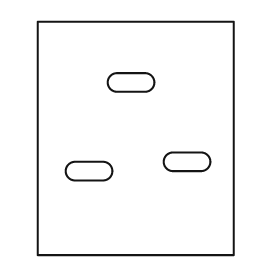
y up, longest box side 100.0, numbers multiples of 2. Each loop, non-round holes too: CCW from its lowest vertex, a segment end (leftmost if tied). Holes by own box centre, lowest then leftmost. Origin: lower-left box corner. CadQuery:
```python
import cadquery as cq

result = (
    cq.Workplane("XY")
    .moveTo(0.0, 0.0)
    .lineTo(84.0, 0.0)
    .lineTo(84.0, 100.0)
    .lineTo(0.0, 100.0)
    .close()
    .moveTo(16.0, 32.0)
    .lineTo(28.0, 32.0)
    .threePointArc((32.0, 36.0), (28.0, 40.0))
    .lineTo(16.0, 40.0)
    .threePointArc((12.0, 36.0), (16.0, 32.0))
    .close()
    .moveTo(58.0, 36.0)
    .lineTo(70.0, 36.0)
    .threePointArc((74.0, 40.0), (70.0, 44.0))
    .lineTo(58.0, 44.0)
    .threePointArc((54.0, 40.0), (58.0, 36.0))
    .close()
    .moveTo(34.0, 70.0)
    .lineTo(46.0, 70.0)
    .threePointArc((50.0, 74.0), (46.0, 78.0))
    .lineTo(34.0, 78.0)
    .threePointArc((30.0, 74.0), (34.0, 70.0))
    .close()
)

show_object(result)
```